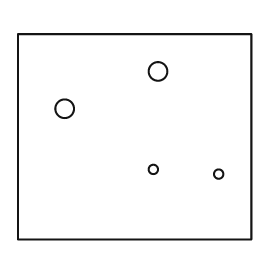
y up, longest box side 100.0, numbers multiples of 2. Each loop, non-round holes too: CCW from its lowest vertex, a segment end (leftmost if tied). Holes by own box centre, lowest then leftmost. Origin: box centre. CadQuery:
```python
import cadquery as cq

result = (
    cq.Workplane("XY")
    .moveTo(-50.0, -44.0)
    .lineTo(50.0, -44.0)
    .lineTo(50.0, 44.0)
    .lineTo(-50.0, 44.0)
    .close()
    .moveTo(36.0, -16.0)
    .circle(2.0)
    .moveTo(8.0, -14.0)
    .circle(2.0)
    .moveTo(-30.0, 12.0)
    .circle(4.0)
    .moveTo(10.0, 28.0)
    .circle(4.0)
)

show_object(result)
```